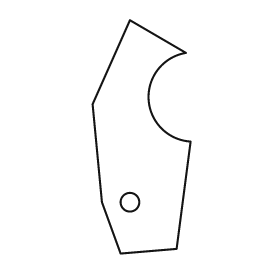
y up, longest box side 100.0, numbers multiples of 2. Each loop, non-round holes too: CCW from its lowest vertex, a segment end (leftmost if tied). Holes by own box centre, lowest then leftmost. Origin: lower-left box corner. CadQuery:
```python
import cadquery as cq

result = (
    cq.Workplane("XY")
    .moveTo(12.0, 0.0)
    .lineTo(36.0, 2.0)
    .lineTo(42.0, 48.0)
    .threePointArc((24.0, 66.0), (40.0, 86.0))
    .lineTo(16.0, 100.0)
    .lineTo(0.0, 64.0)
    .lineTo(4.0, 22.0)
    .close()
    .moveTo(16.0, 22.0)
    .circle(4.0)
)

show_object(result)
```